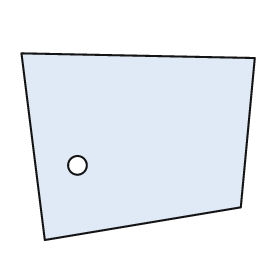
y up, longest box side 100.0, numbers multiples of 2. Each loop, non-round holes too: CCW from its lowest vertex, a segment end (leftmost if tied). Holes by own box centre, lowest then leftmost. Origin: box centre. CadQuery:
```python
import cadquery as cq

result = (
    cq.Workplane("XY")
    .moveTo(-40.0, -40.0)
    .lineTo(44.0, -26.0)
    .lineTo(50.0, 38.0)
    .lineTo(-50.0, 40.0)
    .close()
    .moveTo(-26.0, -8.0)
    .circle(4.0)
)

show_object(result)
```